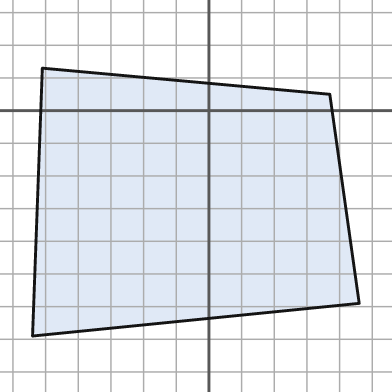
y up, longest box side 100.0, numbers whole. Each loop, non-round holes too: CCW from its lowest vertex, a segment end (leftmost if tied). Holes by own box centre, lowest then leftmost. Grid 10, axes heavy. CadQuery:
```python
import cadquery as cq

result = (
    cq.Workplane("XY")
    .moveTo(-54.0, -69.0)
    .lineTo(46.0, -59.0)
    .lineTo(37.0, 5.0)
    .lineTo(-51.0, 13.0)
    .close()
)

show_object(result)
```